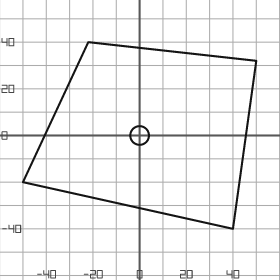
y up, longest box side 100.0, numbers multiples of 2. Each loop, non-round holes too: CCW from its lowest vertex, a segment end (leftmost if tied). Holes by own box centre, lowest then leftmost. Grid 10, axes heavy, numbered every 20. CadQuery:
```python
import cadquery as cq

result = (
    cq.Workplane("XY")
    .moveTo(40.0, -40.0)
    .lineTo(50.0, 32.0)
    .lineTo(-22.0, 40.0)
    .lineTo(-50.0, -20.0)
    .close()
    .moveTo(0.0, 0.0)
    .circle(4.0)
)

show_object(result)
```